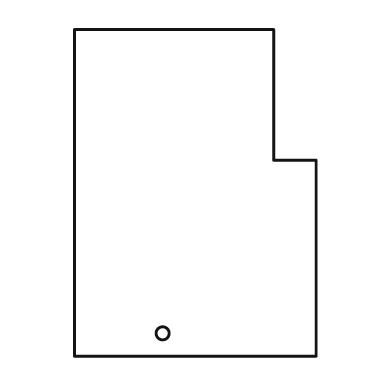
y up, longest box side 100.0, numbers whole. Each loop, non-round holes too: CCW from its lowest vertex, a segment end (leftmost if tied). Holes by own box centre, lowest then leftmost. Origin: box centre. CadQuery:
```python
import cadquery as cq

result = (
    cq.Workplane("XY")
    .moveTo(-37.0, -50.0)
    .lineTo(37.0, -50.0)
    .lineTo(37.0, 10.0)
    .lineTo(24.0, 10.0)
    .lineTo(24.0, 50.0)
    .lineTo(-37.0, 50.0)
    .close()
    .moveTo(-10.0, -43.0)
    .circle(2.0)
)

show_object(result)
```